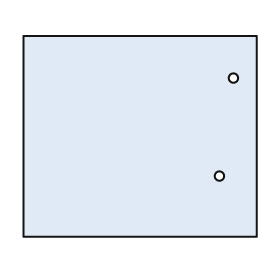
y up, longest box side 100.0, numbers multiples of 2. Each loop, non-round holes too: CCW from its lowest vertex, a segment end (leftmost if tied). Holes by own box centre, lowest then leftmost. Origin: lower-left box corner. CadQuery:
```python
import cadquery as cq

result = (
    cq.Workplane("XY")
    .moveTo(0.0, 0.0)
    .lineTo(100.0, 0.0)
    .lineTo(100.0, 86.0)
    .lineTo(0.0, 86.0)
    .close()
    .moveTo(84.0, 26.0)
    .circle(2.0)
    .moveTo(90.0, 68.0)
    .circle(2.0)
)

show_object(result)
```